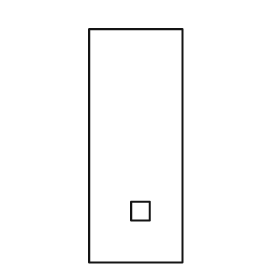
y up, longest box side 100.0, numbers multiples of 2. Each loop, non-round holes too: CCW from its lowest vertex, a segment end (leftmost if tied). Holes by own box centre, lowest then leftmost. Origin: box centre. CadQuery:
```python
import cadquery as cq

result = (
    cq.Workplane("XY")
    .moveTo(-20.0, -50.0)
    .lineTo(20.0, -50.0)
    .lineTo(20.0, 50.0)
    .lineTo(-20.0, 50.0)
    .close()
    .moveTo(-2.0, -32.0)
    .lineTo(6.0, -32.0)
    .lineTo(6.0, -24.0)
    .lineTo(-2.0, -24.0)
    .close()
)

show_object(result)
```